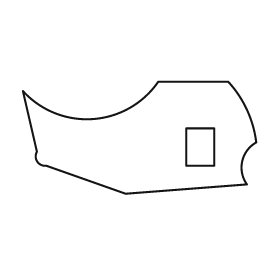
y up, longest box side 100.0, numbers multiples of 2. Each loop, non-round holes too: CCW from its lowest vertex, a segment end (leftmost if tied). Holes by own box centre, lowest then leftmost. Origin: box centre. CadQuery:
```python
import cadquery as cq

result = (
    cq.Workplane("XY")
    .moveTo(-6.0, -24.0)
    .lineTo(46.0, -20.0)
    .threePointArc((44.0, -10.0), (50.0, -2.0))
    .threePointArc((46.0, 12.0), (38.0, 24.0))
    .lineTo(8.0, 24.0)
    .threePointArc((-20.0, 8.0), (-50.0, 20.0))
    .lineTo(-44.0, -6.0)
    .threePointArc((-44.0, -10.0), (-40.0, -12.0))
    .close()
    .moveTo(20.0, -12.0)
    .lineTo(32.0, -12.0)
    .lineTo(32.0, 4.0)
    .lineTo(20.0, 4.0)
    .close()
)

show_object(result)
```